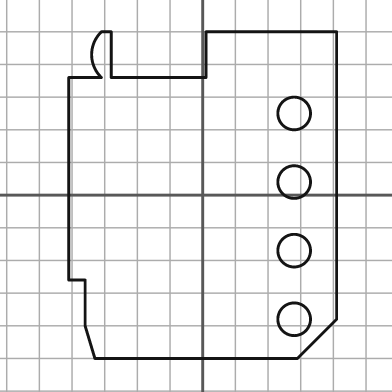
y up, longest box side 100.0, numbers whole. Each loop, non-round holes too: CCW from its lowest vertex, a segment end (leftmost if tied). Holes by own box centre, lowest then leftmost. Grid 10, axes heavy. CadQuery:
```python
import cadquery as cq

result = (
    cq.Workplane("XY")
    .moveTo(-33.0, -50.0)
    .lineTo(29.0, -50.0)
    .lineTo(41.0, -38.0)
    .lineTo(41.0, 50.0)
    .lineTo(1.0, 50.0)
    .lineTo(1.0, 36.0)
    .lineTo(-28.0, 36.0)
    .lineTo(-28.0, 50.0)
    .lineTo(-31.0, 50.0)
    .threePointArc((-34.0, 43.0), (-31.0, 36.0))
    .lineTo(-41.0, 36.0)
    .lineTo(-41.0, -26.0)
    .lineTo(-36.0, -26.0)
    .lineTo(-36.0, -40.0)
    .close()
    .moveTo(28.0, -38.0)
    .circle(5.0)
    .moveTo(28.0, -17.0)
    .circle(5.0)
    .moveTo(28.0, 4.0)
    .circle(5.0)
    .moveTo(28.0, 25.0)
    .circle(5.0)
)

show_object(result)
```